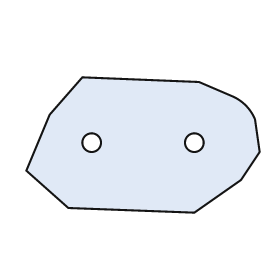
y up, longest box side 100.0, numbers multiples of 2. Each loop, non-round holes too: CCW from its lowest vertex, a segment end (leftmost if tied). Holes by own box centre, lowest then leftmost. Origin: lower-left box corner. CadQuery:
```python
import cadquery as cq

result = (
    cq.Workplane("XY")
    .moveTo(72.0, 0.0)
    .lineTo(92.0, 14.0)
    .lineTo(100.0, 26.0)
    .lineTo(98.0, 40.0)
    .threePointArc((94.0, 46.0), (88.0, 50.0))
    .lineTo(74.0, 56.0)
    .lineTo(24.0, 58.0)
    .lineTo(10.0, 42.0)
    .lineTo(0.0, 18.0)
    .lineTo(18.0, 2.0)
    .close()
    .moveTo(28.0, 30.0)
    .circle(4.0)
    .moveTo(72.0, 30.0)
    .circle(4.0)
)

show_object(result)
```